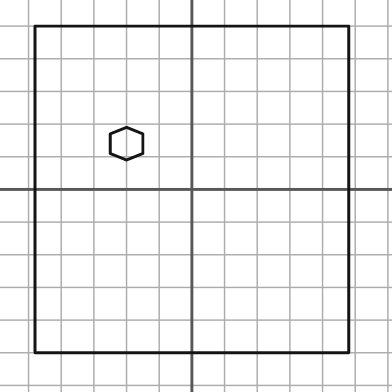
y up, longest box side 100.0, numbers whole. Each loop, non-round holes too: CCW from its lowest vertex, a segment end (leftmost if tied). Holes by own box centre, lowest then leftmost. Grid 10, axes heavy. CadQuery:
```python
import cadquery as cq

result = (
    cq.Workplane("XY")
    .moveTo(-48.0, -50.0)
    .lineTo(48.0, -50.0)
    .lineTo(48.0, 50.0)
    .lineTo(-48.0, 50.0)
    .close()
    .moveTo(-20.0, 9.0)
    .lineTo(-15.0, 11.0)
    .lineTo(-15.0, 17.0)
    .lineTo(-20.0, 19.0)
    .lineTo(-25.0, 17.0)
    .lineTo(-25.0, 11.0)
    .close()
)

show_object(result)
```